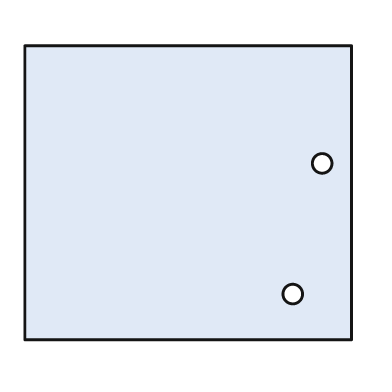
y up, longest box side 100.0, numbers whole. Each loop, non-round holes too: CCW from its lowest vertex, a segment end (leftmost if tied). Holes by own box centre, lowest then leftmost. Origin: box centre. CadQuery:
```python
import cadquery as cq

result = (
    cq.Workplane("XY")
    .moveTo(-50.0, -45.0)
    .lineTo(50.0, -45.0)
    .lineTo(50.0, 45.0)
    .lineTo(-50.0, 45.0)
    .close()
    .moveTo(32.0, -31.0)
    .circle(3.0)
    .moveTo(41.0, 9.0)
    .circle(3.0)
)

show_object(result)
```